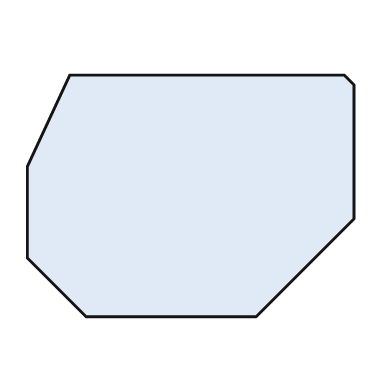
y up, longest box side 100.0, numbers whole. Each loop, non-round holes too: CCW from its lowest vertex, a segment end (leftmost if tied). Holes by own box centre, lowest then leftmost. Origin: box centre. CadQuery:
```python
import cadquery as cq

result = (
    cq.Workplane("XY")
    .moveTo(-32.0, -37.0)
    .lineTo(20.0, -37.0)
    .lineTo(50.0, -7.0)
    .lineTo(50.0, 34.0)
    .lineTo(47.0, 37.0)
    .lineTo(-37.0, 37.0)
    .lineTo(-50.0, 9.0)
    .lineTo(-50.0, -19.0)
    .close()
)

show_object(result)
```